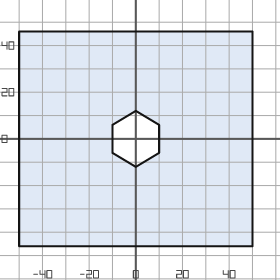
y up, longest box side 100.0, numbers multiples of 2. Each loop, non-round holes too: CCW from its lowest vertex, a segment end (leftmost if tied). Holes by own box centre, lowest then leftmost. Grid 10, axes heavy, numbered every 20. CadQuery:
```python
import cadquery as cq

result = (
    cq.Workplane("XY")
    .moveTo(-50.0, -46.0)
    .lineTo(50.0, -46.0)
    .lineTo(50.0, 46.0)
    .lineTo(-50.0, 46.0)
    .close()
    .moveTo(0.0, -12.0)
    .lineTo(10.0, -6.0)
    .lineTo(10.0, 6.0)
    .lineTo(0.0, 12.0)
    .lineTo(-10.0, 6.0)
    .lineTo(-10.0, -6.0)
    .close()
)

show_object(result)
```